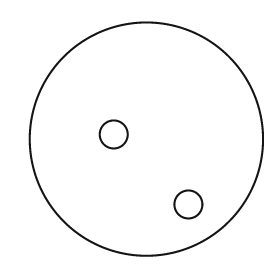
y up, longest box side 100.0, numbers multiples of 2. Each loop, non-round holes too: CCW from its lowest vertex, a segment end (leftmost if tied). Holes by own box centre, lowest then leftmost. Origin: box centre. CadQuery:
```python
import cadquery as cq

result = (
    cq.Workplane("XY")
    .moveTo(0.0, 0.0)
    .circle(50.0)
    .moveTo(18.0, -28.0)
    .circle(6.0)
    .moveTo(-14.0, 2.0)
    .circle(6.0)
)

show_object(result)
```